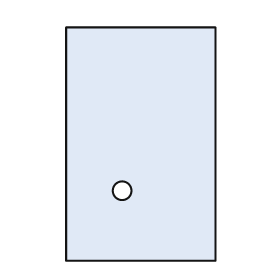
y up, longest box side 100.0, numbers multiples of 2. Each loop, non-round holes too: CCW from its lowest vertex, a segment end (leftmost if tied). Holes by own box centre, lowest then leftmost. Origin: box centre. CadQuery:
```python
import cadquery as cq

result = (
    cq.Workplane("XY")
    .moveTo(-32.0, -50.0)
    .lineTo(32.0, -50.0)
    .lineTo(32.0, 50.0)
    .lineTo(-32.0, 50.0)
    .close()
    .moveTo(-8.0, -20.0)
    .circle(4.0)
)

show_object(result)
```